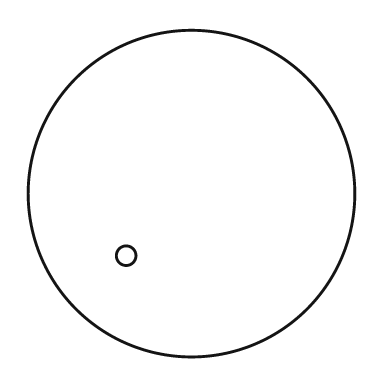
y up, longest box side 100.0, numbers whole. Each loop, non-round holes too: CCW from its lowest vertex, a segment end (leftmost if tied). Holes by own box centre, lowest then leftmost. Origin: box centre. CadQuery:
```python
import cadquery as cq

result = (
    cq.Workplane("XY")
    .moveTo(0.0, 0.0)
    .circle(50.0)
    .moveTo(-20.0, -19.0)
    .circle(3.0)
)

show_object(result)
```